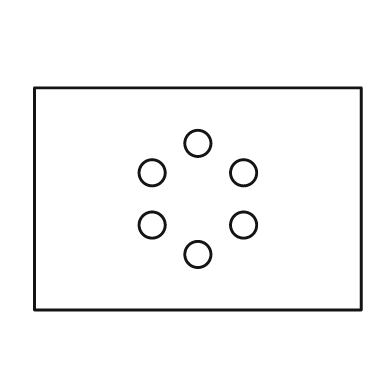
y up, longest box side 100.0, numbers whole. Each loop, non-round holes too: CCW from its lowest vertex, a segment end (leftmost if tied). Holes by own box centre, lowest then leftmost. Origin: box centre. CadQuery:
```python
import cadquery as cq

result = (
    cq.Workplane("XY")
    .moveTo(-50.0, -34.0)
    .lineTo(50.0, -34.0)
    .lineTo(50.0, 34.0)
    .lineTo(-50.0, 34.0)
    .close()
    .moveTo(0.0, -17.0)
    .circle(4.0)
    .moveTo(-14.0, -8.0)
    .circle(4.0)
    .moveTo(14.0, -8.0)
    .circle(4.0)
    .moveTo(-14.0, 8.0)
    .circle(4.0)
    .moveTo(14.0, 8.0)
    .circle(4.0)
    .moveTo(0.0, 17.0)
    .circle(4.0)
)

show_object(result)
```